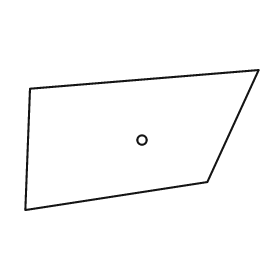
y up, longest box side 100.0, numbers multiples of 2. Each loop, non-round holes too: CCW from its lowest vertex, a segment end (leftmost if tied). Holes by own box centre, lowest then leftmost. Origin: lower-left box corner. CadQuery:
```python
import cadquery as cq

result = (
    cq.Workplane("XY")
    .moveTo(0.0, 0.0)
    .lineTo(78.0, 12.0)
    .lineTo(100.0, 60.0)
    .lineTo(2.0, 52.0)
    .close()
    .moveTo(50.0, 30.0)
    .circle(2.0)
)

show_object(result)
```